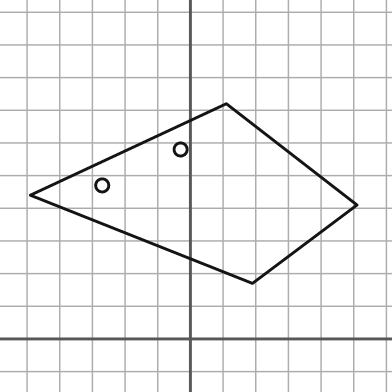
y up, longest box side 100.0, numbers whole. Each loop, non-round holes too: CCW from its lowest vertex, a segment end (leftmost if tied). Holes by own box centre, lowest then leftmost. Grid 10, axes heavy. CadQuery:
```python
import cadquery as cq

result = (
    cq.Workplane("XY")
    .moveTo(19.0, 17.0)
    .lineTo(51.0, 41.0)
    .lineTo(11.0, 72.0)
    .lineTo(-49.0, 44.0)
    .close()
    .moveTo(-27.0, 47.0)
    .circle(2.0)
    .moveTo(-3.0, 58.0)
    .circle(2.0)
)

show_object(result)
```